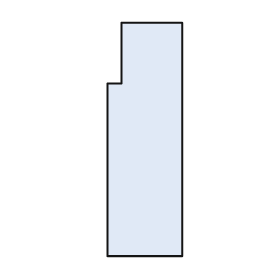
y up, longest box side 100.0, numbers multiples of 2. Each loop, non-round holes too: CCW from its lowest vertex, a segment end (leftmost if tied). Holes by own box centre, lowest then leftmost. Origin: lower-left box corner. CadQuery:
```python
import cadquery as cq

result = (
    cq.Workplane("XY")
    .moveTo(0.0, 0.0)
    .lineTo(32.0, 0.0)
    .lineTo(32.0, 100.0)
    .lineTo(6.0, 100.0)
    .lineTo(6.0, 74.0)
    .lineTo(0.0, 74.0)
    .close()
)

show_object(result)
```